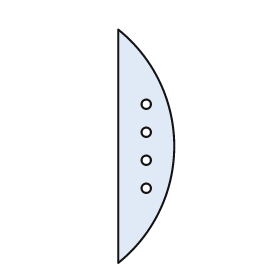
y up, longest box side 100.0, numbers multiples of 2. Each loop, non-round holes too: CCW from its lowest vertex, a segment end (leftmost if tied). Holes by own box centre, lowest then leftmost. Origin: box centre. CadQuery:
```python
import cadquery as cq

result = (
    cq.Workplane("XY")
    .moveTo(-12.0, -50.0)
    .threePointArc((12.0, 0.0), (-12.0, 50.0))
    .close()
    .moveTo(0.0, -18.0)
    .circle(2.0)
    .moveTo(0.0, -6.0)
    .circle(2.0)
    .moveTo(0.0, 6.0)
    .circle(2.0)
    .moveTo(0.0, 18.0)
    .circle(2.0)
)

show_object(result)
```